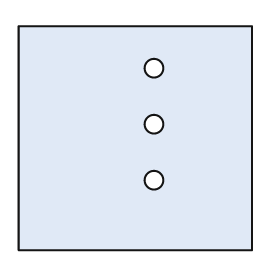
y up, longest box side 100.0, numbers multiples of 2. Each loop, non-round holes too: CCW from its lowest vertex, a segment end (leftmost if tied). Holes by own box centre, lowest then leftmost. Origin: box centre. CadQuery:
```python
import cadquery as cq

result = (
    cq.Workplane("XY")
    .moveTo(-50.0, -48.0)
    .lineTo(50.0, -48.0)
    .lineTo(50.0, 48.0)
    .lineTo(-50.0, 48.0)
    .close()
    .moveTo(8.0, -18.0)
    .circle(4.0)
    .moveTo(8.0, 6.0)
    .circle(4.0)
    .moveTo(8.0, 30.0)
    .circle(4.0)
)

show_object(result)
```